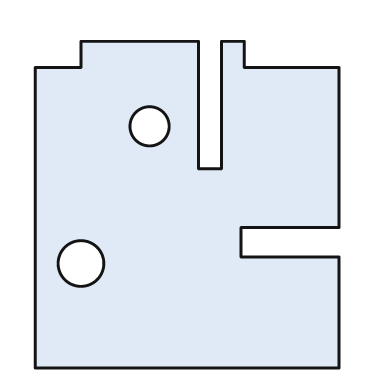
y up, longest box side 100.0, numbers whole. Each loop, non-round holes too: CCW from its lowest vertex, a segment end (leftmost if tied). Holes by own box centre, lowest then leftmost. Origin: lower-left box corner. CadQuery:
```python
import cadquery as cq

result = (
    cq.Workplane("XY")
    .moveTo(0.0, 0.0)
    .lineTo(93.0, 0.0)
    .lineTo(93.0, 34.0)
    .lineTo(63.0, 34.0)
    .lineTo(63.0, 43.0)
    .lineTo(93.0, 43.0)
    .lineTo(93.0, 92.0)
    .lineTo(64.0, 92.0)
    .lineTo(64.0, 100.0)
    .lineTo(57.0, 100.0)
    .lineTo(57.0, 61.0)
    .lineTo(50.0, 61.0)
    .lineTo(50.0, 100.0)
    .lineTo(14.0, 100.0)
    .lineTo(14.0, 92.0)
    .lineTo(0.0, 92.0)
    .close()
    .moveTo(14.0, 32.0)
    .circle(7.0)
    .moveTo(35.0, 74.0)
    .circle(6.0)
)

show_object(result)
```